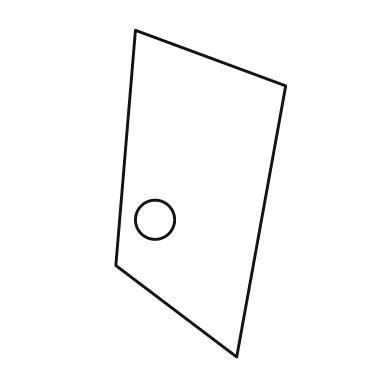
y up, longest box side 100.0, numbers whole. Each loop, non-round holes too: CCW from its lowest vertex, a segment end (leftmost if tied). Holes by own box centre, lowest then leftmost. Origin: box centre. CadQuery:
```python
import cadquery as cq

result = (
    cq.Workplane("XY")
    .moveTo(11.0, -50.0)
    .lineTo(26.0, 33.0)
    .lineTo(-20.0, 50.0)
    .lineTo(-26.0, -22.0)
    .close()
    .moveTo(-14.0, -8.0)
    .circle(6.0)
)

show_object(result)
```